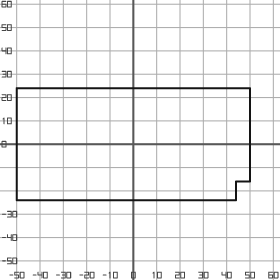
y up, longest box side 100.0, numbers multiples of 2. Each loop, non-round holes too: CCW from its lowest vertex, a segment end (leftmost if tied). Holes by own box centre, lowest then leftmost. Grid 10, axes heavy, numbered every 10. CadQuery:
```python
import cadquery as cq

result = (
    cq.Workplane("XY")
    .moveTo(-50.0, -24.0)
    .lineTo(44.0, -24.0)
    .lineTo(44.0, -16.0)
    .lineTo(50.0, -16.0)
    .lineTo(50.0, 24.0)
    .lineTo(-50.0, 24.0)
    .close()
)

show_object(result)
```